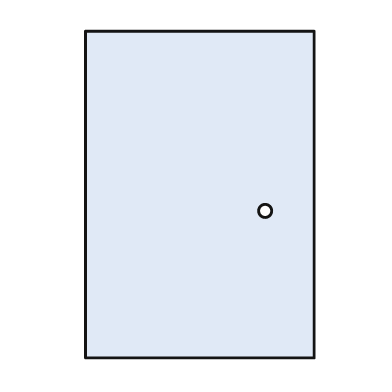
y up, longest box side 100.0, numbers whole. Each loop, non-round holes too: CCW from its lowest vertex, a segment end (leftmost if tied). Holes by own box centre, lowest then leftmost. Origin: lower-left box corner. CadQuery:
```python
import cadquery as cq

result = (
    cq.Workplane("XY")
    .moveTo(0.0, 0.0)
    .lineTo(70.0, 0.0)
    .lineTo(70.0, 100.0)
    .lineTo(0.0, 100.0)
    .close()
    .moveTo(55.0, 45.0)
    .circle(2.0)
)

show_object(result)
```